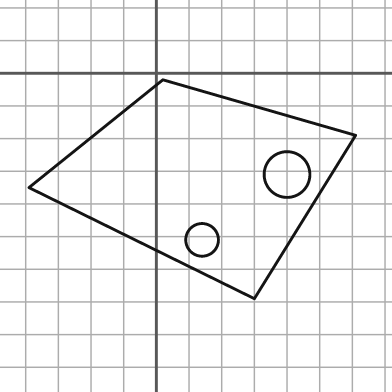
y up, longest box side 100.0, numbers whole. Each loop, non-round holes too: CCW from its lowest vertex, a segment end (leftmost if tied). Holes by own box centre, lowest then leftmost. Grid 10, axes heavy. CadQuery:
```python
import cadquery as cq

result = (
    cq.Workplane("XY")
    .moveTo(30.0, -69.0)
    .lineTo(61.0, -19.0)
    .lineTo(2.0, -2.0)
    .lineTo(-39.0, -35.0)
    .close()
    .moveTo(14.0, -51.0)
    .circle(5.0)
    .moveTo(40.0, -31.0)
    .circle(7.0)
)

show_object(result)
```